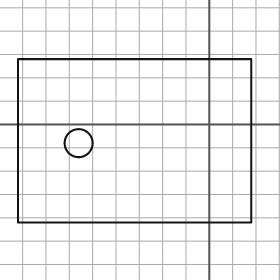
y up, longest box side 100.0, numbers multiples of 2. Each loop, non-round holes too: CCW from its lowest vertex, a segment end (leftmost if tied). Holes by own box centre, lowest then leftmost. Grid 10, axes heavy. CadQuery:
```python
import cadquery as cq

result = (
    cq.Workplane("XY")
    .moveTo(-82.0, -42.0)
    .lineTo(18.0, -42.0)
    .lineTo(18.0, 28.0)
    .lineTo(-82.0, 28.0)
    .close()
    .moveTo(-56.0, -8.0)
    .circle(6.0)
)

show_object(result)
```